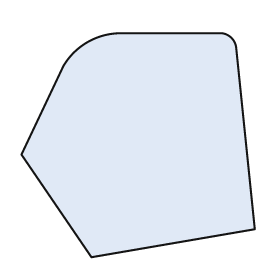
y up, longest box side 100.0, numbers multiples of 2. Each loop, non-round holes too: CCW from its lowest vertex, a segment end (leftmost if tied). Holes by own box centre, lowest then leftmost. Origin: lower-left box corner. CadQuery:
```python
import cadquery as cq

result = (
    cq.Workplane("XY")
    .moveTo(30.0, 0.0)
    .lineTo(100.0, 12.0)
    .lineTo(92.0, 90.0)
    .threePointArc((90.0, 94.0), (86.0, 96.0))
    .lineTo(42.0, 96.0)
    .threePointArc((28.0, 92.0), (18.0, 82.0))
    .lineTo(0.0, 44.0)
    .close()
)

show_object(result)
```